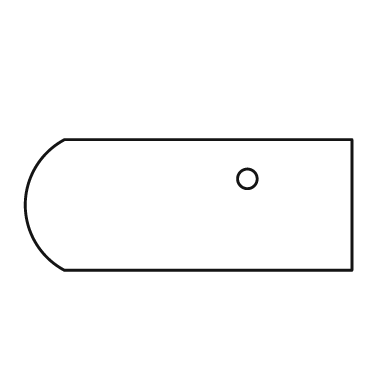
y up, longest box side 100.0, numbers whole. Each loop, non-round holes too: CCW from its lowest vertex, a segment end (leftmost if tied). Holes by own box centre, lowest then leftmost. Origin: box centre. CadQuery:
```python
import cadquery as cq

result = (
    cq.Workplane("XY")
    .moveTo(-38.0, -20.0)
    .lineTo(50.0, -20.0)
    .lineTo(50.0, 20.0)
    .lineTo(-38.0, 20.0)
    .threePointArc((-50.0, 0.0), (-38.0, -20.0))
    .close()
    .moveTo(18.0, 8.0)
    .circle(3.0)
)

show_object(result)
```